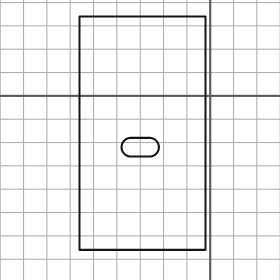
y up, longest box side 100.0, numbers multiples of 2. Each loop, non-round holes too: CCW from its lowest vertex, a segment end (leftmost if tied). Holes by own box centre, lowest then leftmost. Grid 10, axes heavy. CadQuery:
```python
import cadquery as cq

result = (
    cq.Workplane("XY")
    .moveTo(-56.0, -66.0)
    .lineTo(-2.0, -66.0)
    .lineTo(-2.0, 34.0)
    .lineTo(-56.0, 34.0)
    .close()
    .moveTo(-34.0, -26.0)
    .lineTo(-26.0, -26.0)
    .threePointArc((-22.0, -22.0), (-26.0, -18.0))
    .lineTo(-34.0, -18.0)
    .threePointArc((-38.0, -22.0), (-34.0, -26.0))
    .close()
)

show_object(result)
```